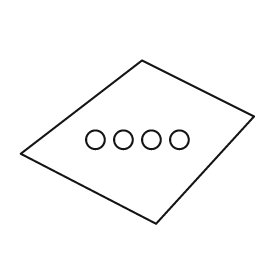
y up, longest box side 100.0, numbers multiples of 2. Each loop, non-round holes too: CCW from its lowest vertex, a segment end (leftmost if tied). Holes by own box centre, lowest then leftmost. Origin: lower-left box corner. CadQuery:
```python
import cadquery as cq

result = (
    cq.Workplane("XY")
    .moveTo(58.0, 0.0)
    .lineTo(100.0, 46.0)
    .lineTo(52.0, 70.0)
    .lineTo(0.0, 30.0)
    .close()
    .moveTo(32.0, 36.0)
    .circle(4.0)
    .moveTo(44.0, 36.0)
    .circle(4.0)
    .moveTo(56.0, 36.0)
    .circle(4.0)
    .moveTo(68.0, 36.0)
    .circle(4.0)
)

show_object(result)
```